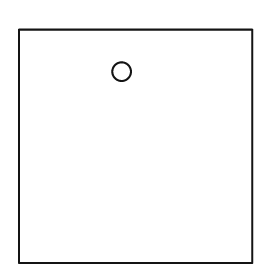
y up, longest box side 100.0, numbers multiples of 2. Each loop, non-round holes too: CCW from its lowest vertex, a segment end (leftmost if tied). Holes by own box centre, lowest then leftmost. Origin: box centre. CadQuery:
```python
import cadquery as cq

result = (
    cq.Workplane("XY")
    .moveTo(-50.0, -50.0)
    .lineTo(50.0, -50.0)
    .lineTo(50.0, 50.0)
    .lineTo(-50.0, 50.0)
    .close()
    .moveTo(-6.0, 32.0)
    .circle(4.0)
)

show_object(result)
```